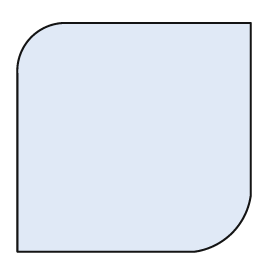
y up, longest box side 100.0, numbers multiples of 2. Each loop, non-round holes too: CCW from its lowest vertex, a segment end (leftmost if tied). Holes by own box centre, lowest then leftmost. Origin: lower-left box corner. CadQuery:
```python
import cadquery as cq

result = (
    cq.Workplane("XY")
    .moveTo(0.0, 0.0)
    .lineTo(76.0, 0.0)
    .threePointArc((92.0, 8.0), (100.0, 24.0))
    .lineTo(100.0, 98.0)
    .lineTo(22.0, 98.0)
    .threePointArc((6.0, 92.0), (0.0, 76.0))
    .close()
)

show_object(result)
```